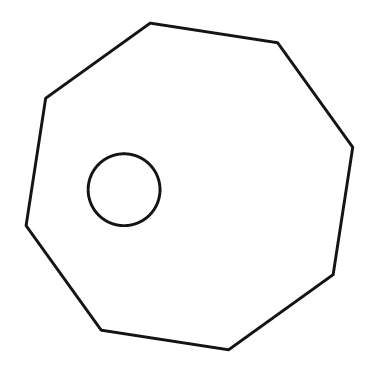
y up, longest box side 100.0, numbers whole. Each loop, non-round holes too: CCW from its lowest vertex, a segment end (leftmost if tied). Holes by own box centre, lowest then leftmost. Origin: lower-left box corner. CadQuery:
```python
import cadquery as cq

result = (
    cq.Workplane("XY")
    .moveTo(62.0, 0.0)
    .lineTo(94.0, 23.0)
    .lineTo(100.0, 62.0)
    .lineTo(77.0, 94.0)
    .lineTo(38.0, 100.0)
    .lineTo(6.0, 77.0)
    .lineTo(0.0, 38.0)
    .lineTo(23.0, 6.0)
    .close()
    .moveTo(30.0, 49.0)
    .circle(11.0)
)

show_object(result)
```